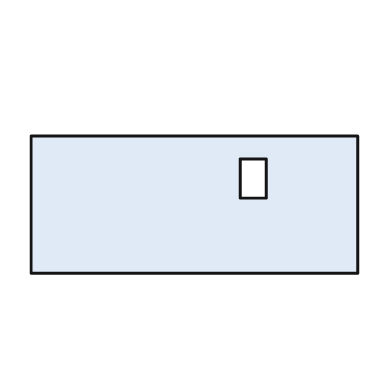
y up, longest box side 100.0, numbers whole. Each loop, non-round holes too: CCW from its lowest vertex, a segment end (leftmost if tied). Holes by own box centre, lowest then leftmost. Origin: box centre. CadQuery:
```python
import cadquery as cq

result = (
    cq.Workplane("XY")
    .moveTo(-50.0, -21.0)
    .lineTo(50.0, -21.0)
    .lineTo(50.0, 21.0)
    .lineTo(-50.0, 21.0)
    .close()
    .moveTo(14.0, 2.0)
    .lineTo(22.0, 2.0)
    .lineTo(22.0, 14.0)
    .lineTo(14.0, 14.0)
    .close()
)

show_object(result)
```